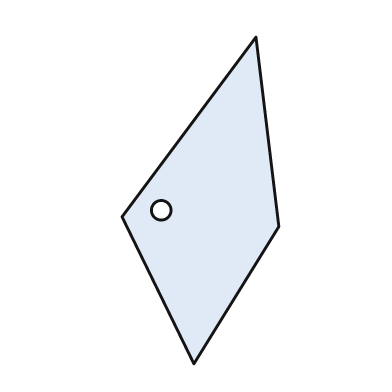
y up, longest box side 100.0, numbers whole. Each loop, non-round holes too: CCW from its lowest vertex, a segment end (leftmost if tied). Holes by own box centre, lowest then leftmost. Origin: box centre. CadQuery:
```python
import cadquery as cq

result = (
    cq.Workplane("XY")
    .moveTo(-2.0, -50.0)
    .lineTo(24.0, -8.0)
    .lineTo(17.0, 50.0)
    .lineTo(-24.0, -5.0)
    .close()
    .moveTo(-12.0, -3.0)
    .circle(3.0)
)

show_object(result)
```